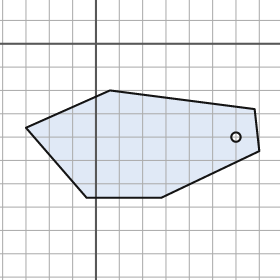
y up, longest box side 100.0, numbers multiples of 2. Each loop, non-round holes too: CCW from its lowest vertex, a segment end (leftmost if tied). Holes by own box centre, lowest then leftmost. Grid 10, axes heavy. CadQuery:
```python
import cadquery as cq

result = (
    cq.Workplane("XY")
    .moveTo(-4.0, -66.0)
    .lineTo(28.0, -66.0)
    .lineTo(70.0, -46.0)
    .lineTo(68.0, -28.0)
    .lineTo(6.0, -20.0)
    .lineTo(-30.0, -36.0)
    .close()
    .moveTo(60.0, -40.0)
    .circle(2.0)
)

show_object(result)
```